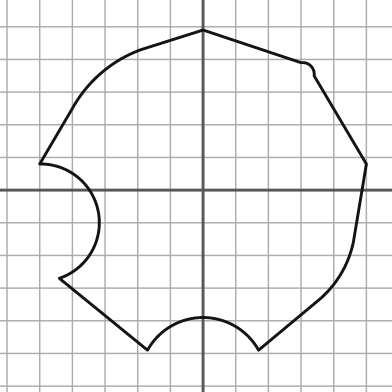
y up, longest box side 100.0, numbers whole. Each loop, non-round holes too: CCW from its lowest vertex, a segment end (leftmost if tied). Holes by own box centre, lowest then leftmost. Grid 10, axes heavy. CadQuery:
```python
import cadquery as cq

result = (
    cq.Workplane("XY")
    .moveTo(-17.0, -49.0)
    .threePointArc((0.0, -39.0), (17.0, -49.0))
    .lineTo(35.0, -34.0)
    .threePointArc((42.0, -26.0), (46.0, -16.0))
    .lineTo(50.0, 8.0)
    .lineTo(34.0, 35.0)
    .threePointArc((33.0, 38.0), (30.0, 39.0))
    .lineTo(0.0, 49.0)
    .lineTo(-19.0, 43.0)
    .threePointArc((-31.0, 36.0), (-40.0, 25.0))
    .lineTo(-50.0, 8.0)
    .threePointArc((-32.0, -7.0), (-44.0, -27.0))
    .close()
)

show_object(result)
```